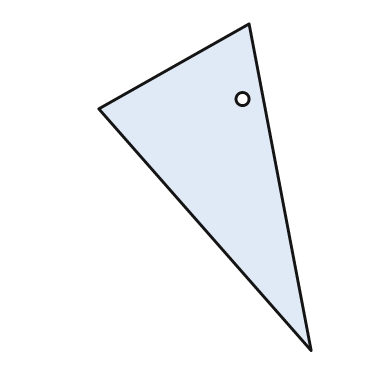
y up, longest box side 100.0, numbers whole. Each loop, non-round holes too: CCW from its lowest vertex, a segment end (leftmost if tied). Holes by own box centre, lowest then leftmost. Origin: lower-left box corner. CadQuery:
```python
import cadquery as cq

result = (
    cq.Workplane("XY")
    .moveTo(65.0, 0.0)
    .lineTo(46.0, 100.0)
    .lineTo(0.0, 74.0)
    .close()
    .moveTo(44.0, 77.0)
    .circle(2.0)
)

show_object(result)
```